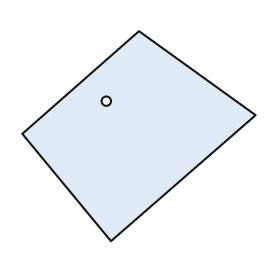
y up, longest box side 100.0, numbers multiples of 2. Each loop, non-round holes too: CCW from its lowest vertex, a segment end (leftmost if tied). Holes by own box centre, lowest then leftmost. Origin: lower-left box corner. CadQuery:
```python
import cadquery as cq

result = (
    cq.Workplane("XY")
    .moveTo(38.0, 0.0)
    .lineTo(100.0, 54.0)
    .lineTo(50.0, 90.0)
    .lineTo(0.0, 46.0)
    .close()
    .moveTo(36.0, 60.0)
    .circle(2.0)
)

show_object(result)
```